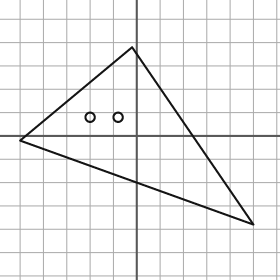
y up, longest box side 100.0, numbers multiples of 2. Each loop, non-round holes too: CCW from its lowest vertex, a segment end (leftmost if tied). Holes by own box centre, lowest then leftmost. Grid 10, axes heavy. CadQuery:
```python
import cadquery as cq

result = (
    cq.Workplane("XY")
    .moveTo(50.0, -38.0)
    .lineTo(-2.0, 38.0)
    .lineTo(-50.0, -2.0)
    .close()
    .moveTo(-20.0, 8.0)
    .circle(2.0)
    .moveTo(-8.0, 8.0)
    .circle(2.0)
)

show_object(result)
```